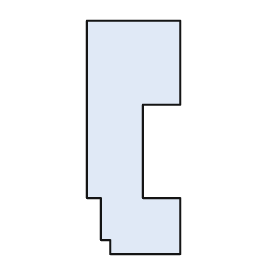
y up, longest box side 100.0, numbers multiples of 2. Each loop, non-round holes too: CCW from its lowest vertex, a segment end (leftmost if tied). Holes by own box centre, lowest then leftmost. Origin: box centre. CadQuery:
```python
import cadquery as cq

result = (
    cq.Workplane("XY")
    .moveTo(-10.0, -50.0)
    .lineTo(20.0, -50.0)
    .lineTo(20.0, -26.0)
    .lineTo(4.0, -26.0)
    .lineTo(4.0, 14.0)
    .lineTo(20.0, 14.0)
    .lineTo(20.0, 50.0)
    .lineTo(-20.0, 50.0)
    .lineTo(-20.0, -26.0)
    .lineTo(-14.0, -26.0)
    .lineTo(-14.0, -44.0)
    .lineTo(-10.0, -44.0)
    .close()
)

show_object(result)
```